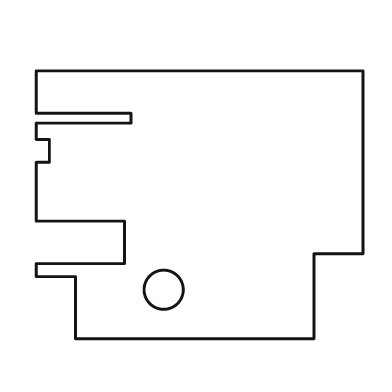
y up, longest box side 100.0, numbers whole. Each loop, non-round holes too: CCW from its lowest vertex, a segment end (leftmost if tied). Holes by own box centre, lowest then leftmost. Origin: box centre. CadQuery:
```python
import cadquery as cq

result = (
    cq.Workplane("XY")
    .moveTo(-38.0, -41.0)
    .lineTo(35.0, -41.0)
    .lineTo(35.0, -15.0)
    .lineTo(50.0, -15.0)
    .lineTo(50.0, 41.0)
    .lineTo(-50.0, 41.0)
    .lineTo(-50.0, 28.0)
    .lineTo(-21.0, 28.0)
    .lineTo(-21.0, 25.0)
    .lineTo(-50.0, 25.0)
    .lineTo(-50.0, 20.0)
    .lineTo(-46.0, 20.0)
    .lineTo(-46.0, 13.0)
    .lineTo(-50.0, 13.0)
    .lineTo(-50.0, -5.0)
    .lineTo(-23.0, -5.0)
    .lineTo(-23.0, -18.0)
    .lineTo(-50.0, -18.0)
    .lineTo(-50.0, -22.0)
    .lineTo(-38.0, -22.0)
    .close()
    .moveTo(-11.0, -26.0)
    .circle(6.0)
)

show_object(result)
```